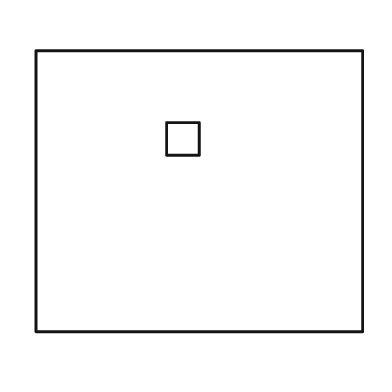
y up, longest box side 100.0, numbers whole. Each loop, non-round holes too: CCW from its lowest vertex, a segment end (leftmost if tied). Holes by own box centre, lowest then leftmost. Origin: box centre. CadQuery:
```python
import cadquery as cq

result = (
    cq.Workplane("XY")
    .moveTo(-50.0, -43.0)
    .lineTo(50.0, -43.0)
    .lineTo(50.0, 43.0)
    .lineTo(-50.0, 43.0)
    .close()
    .moveTo(-10.0, 11.0)
    .lineTo(0.0, 11.0)
    .lineTo(0.0, 21.0)
    .lineTo(-10.0, 21.0)
    .close()
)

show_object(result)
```